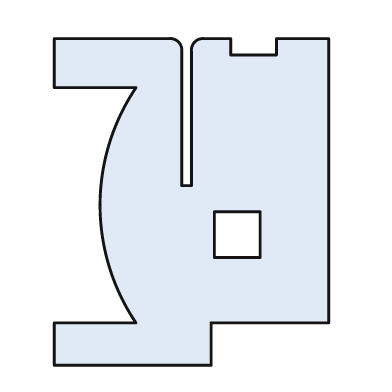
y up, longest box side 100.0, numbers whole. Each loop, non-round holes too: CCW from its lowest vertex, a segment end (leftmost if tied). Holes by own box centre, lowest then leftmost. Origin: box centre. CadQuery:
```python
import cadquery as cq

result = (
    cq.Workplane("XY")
    .moveTo(-42.0, -50.0)
    .lineTo(6.0, -50.0)
    .lineTo(6.0, -37.0)
    .lineTo(42.0, -37.0)
    .lineTo(42.0, 50.0)
    .lineTo(26.0, 50.0)
    .lineTo(26.0, 45.0)
    .lineTo(12.0, 45.0)
    .lineTo(12.0, 50.0)
    .lineTo(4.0, 50.0)
    .threePointArc((1.0, 49.0), (0.0, 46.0))
    .lineTo(0.0, 5.0)
    .lineTo(-3.0, 5.0)
    .lineTo(-3.0, 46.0)
    .threePointArc((-4.0, 49.0), (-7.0, 50.0))
    .lineTo(-42.0, 50.0)
    .lineTo(-42.0, 35.0)
    .lineTo(-17.0, 35.0)
    .threePointArc((-28.0, -1.0), (-17.0, -37.0))
    .lineTo(-42.0, -37.0)
    .close()
    .moveTo(7.0, -17.0)
    .lineTo(21.0, -17.0)
    .lineTo(21.0, -3.0)
    .lineTo(7.0, -3.0)
    .close()
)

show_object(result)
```